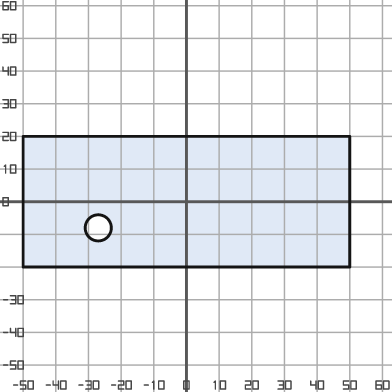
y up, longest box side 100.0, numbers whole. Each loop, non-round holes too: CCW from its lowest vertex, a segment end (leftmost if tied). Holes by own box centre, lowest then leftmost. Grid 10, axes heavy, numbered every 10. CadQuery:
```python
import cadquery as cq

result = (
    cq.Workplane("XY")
    .moveTo(-50.0, -20.0)
    .lineTo(50.0, -20.0)
    .lineTo(50.0, 20.0)
    .lineTo(-50.0, 20.0)
    .close()
    .moveTo(-27.0, -8.0)
    .circle(4.0)
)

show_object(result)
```